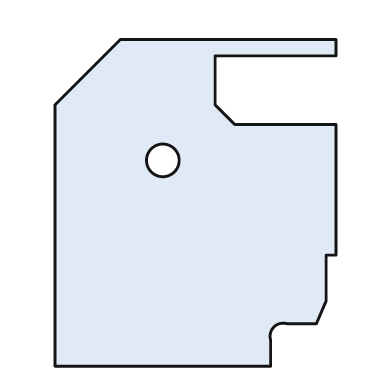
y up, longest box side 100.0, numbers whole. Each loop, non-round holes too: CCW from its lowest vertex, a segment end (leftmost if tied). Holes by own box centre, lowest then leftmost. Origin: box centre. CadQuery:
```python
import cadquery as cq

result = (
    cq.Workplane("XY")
    .moveTo(-43.0, -50.0)
    .lineTo(23.0, -50.0)
    .lineTo(23.0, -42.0)
    .threePointArc((24.0, -38.0), (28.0, -37.0))
    .lineTo(37.0, -37.0)
    .lineTo(40.0, -30.0)
    .lineTo(40.0, -16.0)
    .lineTo(43.0, -16.0)
    .lineTo(43.0, 24.0)
    .lineTo(12.0, 24.0)
    .lineTo(6.0, 30.0)
    .lineTo(6.0, 45.0)
    .lineTo(43.0, 45.0)
    .lineTo(43.0, 50.0)
    .lineTo(-23.0, 50.0)
    .lineTo(-43.0, 30.0)
    .close()
    .moveTo(-10.0, 13.0)
    .circle(5.0)
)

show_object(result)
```